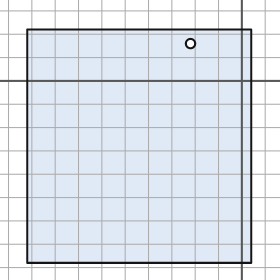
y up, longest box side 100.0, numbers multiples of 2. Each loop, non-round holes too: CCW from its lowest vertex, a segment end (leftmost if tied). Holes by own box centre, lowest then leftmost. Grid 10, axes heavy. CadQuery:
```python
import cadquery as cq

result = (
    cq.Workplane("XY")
    .moveTo(-92.0, -78.0)
    .lineTo(4.0, -78.0)
    .lineTo(4.0, 22.0)
    .lineTo(-92.0, 22.0)
    .close()
    .moveTo(-22.0, 16.0)
    .circle(2.0)
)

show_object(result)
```